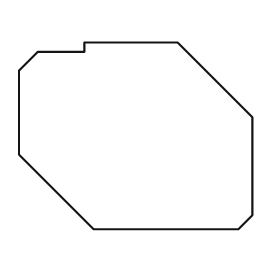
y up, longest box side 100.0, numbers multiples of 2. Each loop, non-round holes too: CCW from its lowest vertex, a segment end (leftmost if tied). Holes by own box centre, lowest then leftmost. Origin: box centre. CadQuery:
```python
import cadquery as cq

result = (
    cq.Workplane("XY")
    .moveTo(-18.0, -40.0)
    .lineTo(44.0, -40.0)
    .lineTo(50.0, -34.0)
    .lineTo(50.0, 8.0)
    .lineTo(18.0, 40.0)
    .lineTo(-22.0, 40.0)
    .lineTo(-22.0, 36.0)
    .lineTo(-42.0, 36.0)
    .lineTo(-50.0, 28.0)
    .lineTo(-50.0, -8.0)
    .close()
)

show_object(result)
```